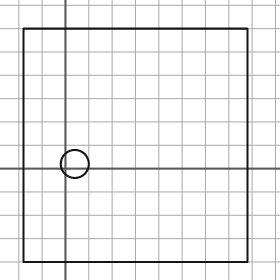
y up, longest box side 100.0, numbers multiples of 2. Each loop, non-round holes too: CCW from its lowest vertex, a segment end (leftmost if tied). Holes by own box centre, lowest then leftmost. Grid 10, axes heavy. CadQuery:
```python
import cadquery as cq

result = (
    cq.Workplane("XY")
    .moveTo(-18.0, -40.0)
    .lineTo(78.0, -40.0)
    .lineTo(78.0, 60.0)
    .lineTo(-18.0, 60.0)
    .close()
    .moveTo(4.0, 2.0)
    .circle(6.0)
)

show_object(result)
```